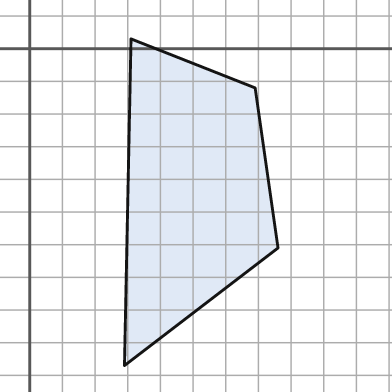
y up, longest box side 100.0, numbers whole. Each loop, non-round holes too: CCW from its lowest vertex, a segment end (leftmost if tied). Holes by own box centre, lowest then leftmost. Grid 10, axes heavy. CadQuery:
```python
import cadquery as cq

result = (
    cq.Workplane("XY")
    .moveTo(29.0, -97.0)
    .lineTo(76.0, -61.0)
    .lineTo(69.0, -12.0)
    .lineTo(31.0, 3.0)
    .close()
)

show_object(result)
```